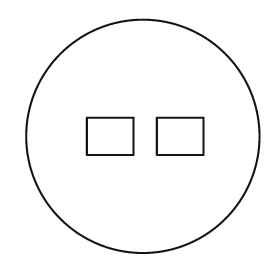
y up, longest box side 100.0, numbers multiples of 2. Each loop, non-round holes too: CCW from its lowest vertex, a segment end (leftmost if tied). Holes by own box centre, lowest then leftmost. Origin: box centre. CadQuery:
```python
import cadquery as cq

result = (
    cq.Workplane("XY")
    .moveTo(0.0, 0.0)
    .circle(50.0)
    .moveTo(-24.0, -8.0)
    .lineTo(-4.0, -8.0)
    .lineTo(-4.0, 8.0)
    .lineTo(-24.0, 8.0)
    .close()
    .moveTo(6.0, -8.0)
    .lineTo(26.0, -8.0)
    .lineTo(26.0, 8.0)
    .lineTo(6.0, 8.0)
    .close()
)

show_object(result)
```